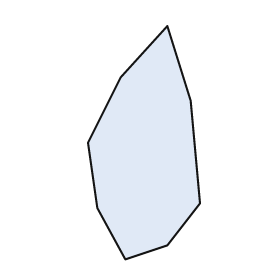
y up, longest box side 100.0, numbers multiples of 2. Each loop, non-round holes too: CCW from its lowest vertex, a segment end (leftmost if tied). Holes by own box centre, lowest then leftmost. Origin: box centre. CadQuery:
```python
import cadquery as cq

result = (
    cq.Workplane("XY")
    .moveTo(-8.0, -50.0)
    .lineTo(10.0, -44.0)
    .lineTo(24.0, -26.0)
    .lineTo(20.0, 18.0)
    .lineTo(10.0, 50.0)
    .lineTo(-10.0, 28.0)
    .lineTo(-24.0, 0.0)
    .lineTo(-20.0, -28.0)
    .close()
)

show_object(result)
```